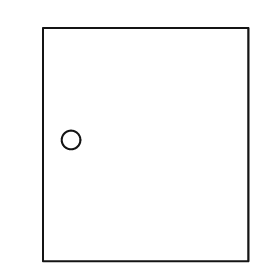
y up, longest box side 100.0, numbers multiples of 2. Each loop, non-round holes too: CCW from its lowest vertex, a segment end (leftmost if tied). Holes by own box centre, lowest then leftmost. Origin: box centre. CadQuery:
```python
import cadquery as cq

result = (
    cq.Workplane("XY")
    .moveTo(-44.0, -50.0)
    .lineTo(44.0, -50.0)
    .lineTo(44.0, 50.0)
    .lineTo(-44.0, 50.0)
    .close()
    .moveTo(-32.0, 2.0)
    .circle(4.0)
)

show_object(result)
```